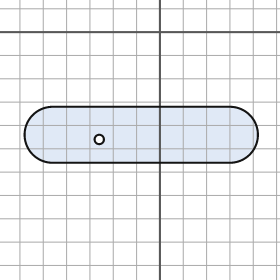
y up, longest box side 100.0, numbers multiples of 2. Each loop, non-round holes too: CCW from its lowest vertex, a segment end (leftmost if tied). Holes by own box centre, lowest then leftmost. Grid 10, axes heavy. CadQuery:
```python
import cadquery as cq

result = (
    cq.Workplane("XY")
    .moveTo(-46.0, -56.0)
    .lineTo(30.0, -56.0)
    .threePointArc((42.0, -44.0), (30.0, -32.0))
    .lineTo(-46.0, -32.0)
    .threePointArc((-58.0, -44.0), (-46.0, -56.0))
    .close()
    .moveTo(-26.0, -46.0)
    .circle(2.0)
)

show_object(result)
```